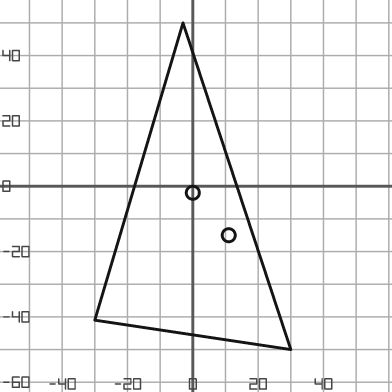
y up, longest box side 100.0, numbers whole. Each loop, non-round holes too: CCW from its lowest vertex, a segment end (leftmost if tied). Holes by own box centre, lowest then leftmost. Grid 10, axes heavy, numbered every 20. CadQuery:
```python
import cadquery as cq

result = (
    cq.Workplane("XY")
    .moveTo(30.0, -50.0)
    .lineTo(-3.0, 50.0)
    .lineTo(-30.0, -41.0)
    .close()
    .moveTo(11.0, -15.0)
    .circle(2.0)
    .moveTo(0.0, -2.0)
    .circle(2.0)
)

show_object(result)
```